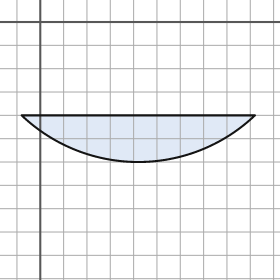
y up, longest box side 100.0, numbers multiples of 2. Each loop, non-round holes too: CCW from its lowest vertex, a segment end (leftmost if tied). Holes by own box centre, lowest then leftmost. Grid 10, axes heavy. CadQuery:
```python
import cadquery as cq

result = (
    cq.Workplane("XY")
    .moveTo(-8.0, -40.0)
    .threePointArc((42.0, -60.0), (92.0, -40.0))
    .close()
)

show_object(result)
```